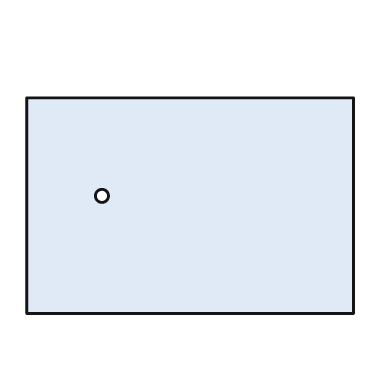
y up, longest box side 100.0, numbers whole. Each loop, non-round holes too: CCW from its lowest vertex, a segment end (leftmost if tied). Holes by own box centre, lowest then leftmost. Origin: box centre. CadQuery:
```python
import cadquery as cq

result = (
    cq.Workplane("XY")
    .moveTo(-50.0, -33.0)
    .lineTo(50.0, -33.0)
    .lineTo(50.0, 33.0)
    .lineTo(-50.0, 33.0)
    .close()
    .moveTo(-27.0, 3.0)
    .circle(2.0)
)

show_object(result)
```